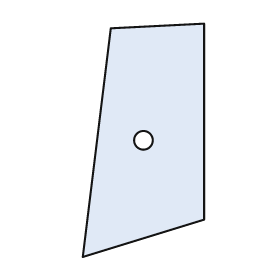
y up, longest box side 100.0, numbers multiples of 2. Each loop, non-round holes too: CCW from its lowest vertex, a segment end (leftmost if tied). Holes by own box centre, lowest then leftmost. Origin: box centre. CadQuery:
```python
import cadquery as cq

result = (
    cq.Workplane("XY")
    .moveTo(-26.0, -50.0)
    .lineTo(26.0, -34.0)
    .lineTo(26.0, 50.0)
    .lineTo(-14.0, 48.0)
    .close()
    .moveTo(0.0, 0.0)
    .circle(4.0)
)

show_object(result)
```